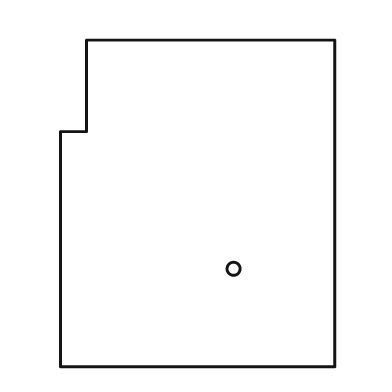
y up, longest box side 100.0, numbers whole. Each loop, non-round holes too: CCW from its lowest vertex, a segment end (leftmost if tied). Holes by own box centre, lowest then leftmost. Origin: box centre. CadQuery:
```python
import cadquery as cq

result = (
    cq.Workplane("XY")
    .moveTo(-42.0, -50.0)
    .lineTo(42.0, -50.0)
    .lineTo(42.0, 50.0)
    .lineTo(-34.0, 50.0)
    .lineTo(-34.0, 22.0)
    .lineTo(-42.0, 22.0)
    .close()
    .moveTo(11.0, -20.0)
    .circle(2.0)
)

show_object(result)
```